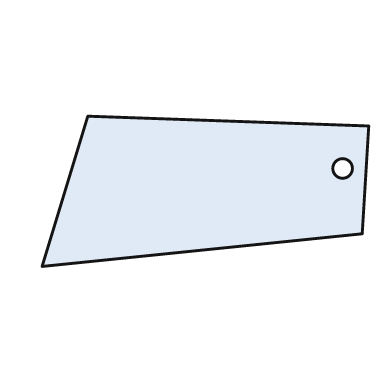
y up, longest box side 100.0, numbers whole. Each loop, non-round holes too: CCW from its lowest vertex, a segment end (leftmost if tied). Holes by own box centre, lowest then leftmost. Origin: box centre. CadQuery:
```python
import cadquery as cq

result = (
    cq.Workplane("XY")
    .moveTo(-50.0, -23.0)
    .lineTo(48.0, -13.0)
    .lineTo(50.0, 20.0)
    .lineTo(-36.0, 23.0)
    .close()
    .moveTo(42.0, 7.0)
    .circle(3.0)
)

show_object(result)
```